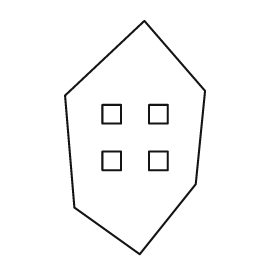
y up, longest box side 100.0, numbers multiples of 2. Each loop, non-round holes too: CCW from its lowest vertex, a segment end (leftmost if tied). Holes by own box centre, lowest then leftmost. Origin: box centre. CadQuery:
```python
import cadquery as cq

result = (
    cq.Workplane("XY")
    .moveTo(2.0, -50.0)
    .lineTo(26.0, -20.0)
    .lineTo(30.0, 20.0)
    .lineTo(4.0, 50.0)
    .lineTo(-30.0, 18.0)
    .lineTo(-26.0, -30.0)
    .close()
    .moveTo(-14.0, -14.0)
    .lineTo(-6.0, -14.0)
    .lineTo(-6.0, -6.0)
    .lineTo(-14.0, -6.0)
    .close()
    .moveTo(6.0, -14.0)
    .lineTo(14.0, -14.0)
    .lineTo(14.0, -6.0)
    .lineTo(6.0, -6.0)
    .close()
    .moveTo(-14.0, 6.0)
    .lineTo(-6.0, 6.0)
    .lineTo(-6.0, 14.0)
    .lineTo(-14.0, 14.0)
    .close()
    .moveTo(6.0, 6.0)
    .lineTo(14.0, 6.0)
    .lineTo(14.0, 14.0)
    .lineTo(6.0, 14.0)
    .close()
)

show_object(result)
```